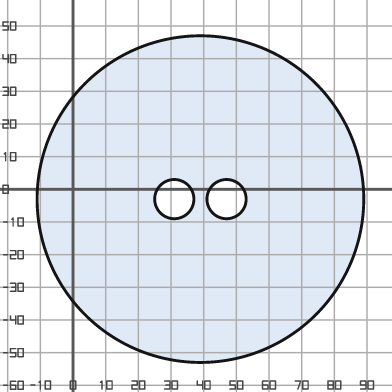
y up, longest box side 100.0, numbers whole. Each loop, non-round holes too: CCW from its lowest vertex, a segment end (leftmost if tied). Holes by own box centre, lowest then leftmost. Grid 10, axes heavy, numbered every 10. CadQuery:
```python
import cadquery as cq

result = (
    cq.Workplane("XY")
    .moveTo(39.0, -3.0)
    .circle(50.0)
    .moveTo(31.0, -3.0)
    .circle(6.0)
    .moveTo(47.0, -3.0)
    .circle(6.0)
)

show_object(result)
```